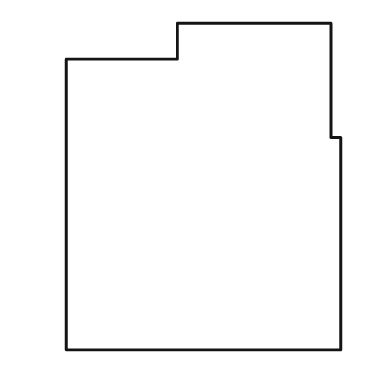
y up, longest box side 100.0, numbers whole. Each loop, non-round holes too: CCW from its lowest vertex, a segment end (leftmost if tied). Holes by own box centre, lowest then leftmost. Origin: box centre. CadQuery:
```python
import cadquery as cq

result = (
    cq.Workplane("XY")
    .moveTo(-42.0, -50.0)
    .lineTo(42.0, -50.0)
    .lineTo(42.0, 15.0)
    .lineTo(39.0, 15.0)
    .lineTo(39.0, 50.0)
    .lineTo(-8.0, 50.0)
    .lineTo(-8.0, 39.0)
    .lineTo(-42.0, 39.0)
    .close()
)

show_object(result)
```